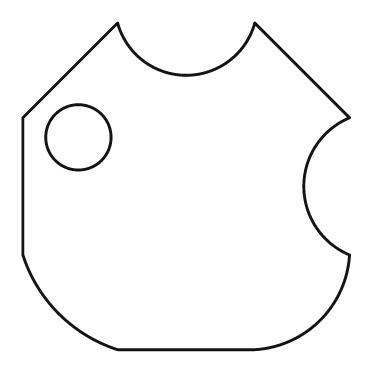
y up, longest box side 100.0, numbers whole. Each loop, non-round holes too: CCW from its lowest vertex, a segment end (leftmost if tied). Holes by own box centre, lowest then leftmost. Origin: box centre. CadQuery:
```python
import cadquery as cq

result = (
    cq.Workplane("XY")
    .moveTo(-21.0, -50.0)
    .lineTo(21.0, -50.0)
    .threePointArc((41.0, -41.0), (50.0, -21.0))
    .threePointArc((36.0, 0.0), (50.0, 21.0))
    .lineTo(21.0, 50.0)
    .threePointArc((0.0, 34.0), (-21.0, 50.0))
    .lineTo(-50.0, 21.0)
    .lineTo(-50.0, -21.0)
    .threePointArc((-39.0, -39.0), (-21.0, -50.0))
    .close()
    .moveTo(-33.0, 15.0)
    .circle(10.0)
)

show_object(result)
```